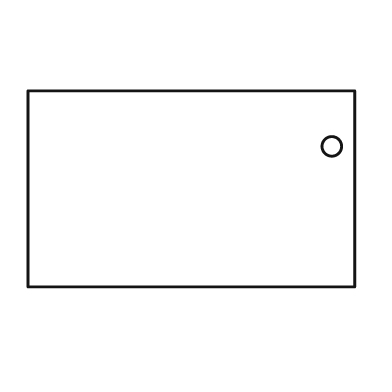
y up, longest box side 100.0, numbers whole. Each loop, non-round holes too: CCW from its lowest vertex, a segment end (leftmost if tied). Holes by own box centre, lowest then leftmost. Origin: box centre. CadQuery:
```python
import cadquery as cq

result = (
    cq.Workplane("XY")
    .moveTo(-50.0, -30.0)
    .lineTo(50.0, -30.0)
    .lineTo(50.0, 30.0)
    .lineTo(-50.0, 30.0)
    .close()
    .moveTo(43.0, 13.0)
    .circle(3.0)
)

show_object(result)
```